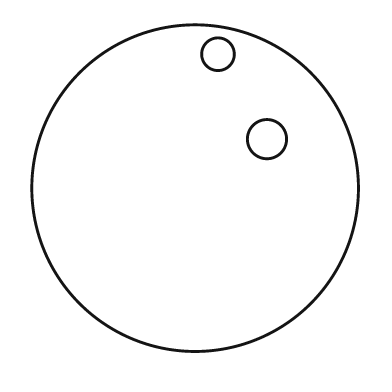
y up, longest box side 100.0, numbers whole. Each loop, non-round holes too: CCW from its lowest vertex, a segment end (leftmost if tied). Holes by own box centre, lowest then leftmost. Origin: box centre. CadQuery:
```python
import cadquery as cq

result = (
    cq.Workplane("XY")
    .moveTo(0.0, 0.0)
    .circle(50.0)
    .moveTo(22.0, 15.0)
    .circle(6.0)
    .moveTo(7.0, 41.0)
    .circle(5.0)
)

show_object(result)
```